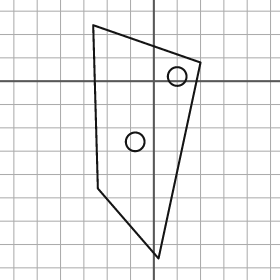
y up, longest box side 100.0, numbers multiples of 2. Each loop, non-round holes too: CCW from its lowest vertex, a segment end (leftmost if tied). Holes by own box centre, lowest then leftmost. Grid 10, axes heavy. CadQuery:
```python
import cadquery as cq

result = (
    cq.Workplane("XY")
    .moveTo(2.0, -76.0)
    .lineTo(20.0, 8.0)
    .lineTo(-26.0, 24.0)
    .lineTo(-24.0, -46.0)
    .close()
    .moveTo(-8.0, -26.0)
    .circle(4.0)
    .moveTo(10.0, 2.0)
    .circle(4.0)
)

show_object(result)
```